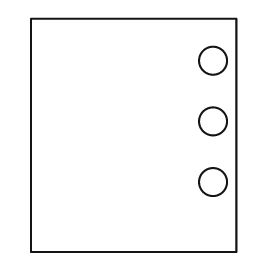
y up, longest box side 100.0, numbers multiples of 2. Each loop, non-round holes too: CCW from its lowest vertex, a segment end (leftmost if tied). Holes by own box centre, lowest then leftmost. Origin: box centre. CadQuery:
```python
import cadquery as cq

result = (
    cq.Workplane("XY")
    .moveTo(-44.0, -50.0)
    .lineTo(44.0, -50.0)
    .lineTo(44.0, 50.0)
    .lineTo(-44.0, 50.0)
    .close()
    .moveTo(34.0, -20.0)
    .circle(6.0)
    .moveTo(34.0, 6.0)
    .circle(6.0)
    .moveTo(34.0, 32.0)
    .circle(6.0)
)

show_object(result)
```